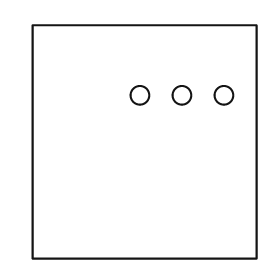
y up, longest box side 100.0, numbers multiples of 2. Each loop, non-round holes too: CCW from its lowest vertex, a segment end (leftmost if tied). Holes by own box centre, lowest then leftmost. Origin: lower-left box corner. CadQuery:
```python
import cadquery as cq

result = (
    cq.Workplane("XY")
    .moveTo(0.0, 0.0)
    .lineTo(96.0, 0.0)
    .lineTo(96.0, 100.0)
    .lineTo(0.0, 100.0)
    .close()
    .moveTo(46.0, 70.0)
    .circle(4.0)
    .moveTo(64.0, 70.0)
    .circle(4.0)
    .moveTo(82.0, 70.0)
    .circle(4.0)
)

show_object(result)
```